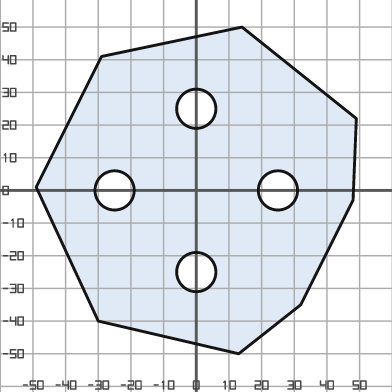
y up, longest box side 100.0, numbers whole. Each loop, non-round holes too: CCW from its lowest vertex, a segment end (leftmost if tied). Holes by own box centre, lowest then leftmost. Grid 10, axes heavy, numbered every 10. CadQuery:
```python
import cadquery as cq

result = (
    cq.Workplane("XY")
    .moveTo(13.0, -50.0)
    .lineTo(32.0, -35.0)
    .lineTo(48.0, -3.0)
    .lineTo(49.0, 22.0)
    .lineTo(14.0, 50.0)
    .lineTo(-29.0, 41.0)
    .lineTo(-49.0, 1.0)
    .lineTo(-30.0, -40.0)
    .close()
    .moveTo(0.0, -25.0)
    .circle(6.0)
    .moveTo(-25.0, 0.0)
    .circle(6.0)
    .moveTo(25.0, 0.0)
    .circle(6.0)
    .moveTo(0.0, 25.0)
    .circle(6.0)
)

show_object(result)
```